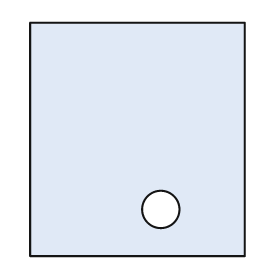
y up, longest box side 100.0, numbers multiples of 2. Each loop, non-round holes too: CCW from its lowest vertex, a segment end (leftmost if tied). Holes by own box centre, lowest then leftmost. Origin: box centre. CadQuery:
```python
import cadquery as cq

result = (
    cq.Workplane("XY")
    .moveTo(-46.0, -50.0)
    .lineTo(46.0, -50.0)
    .lineTo(46.0, 50.0)
    .lineTo(-46.0, 50.0)
    .close()
    .moveTo(10.0, -30.0)
    .circle(8.0)
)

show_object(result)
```